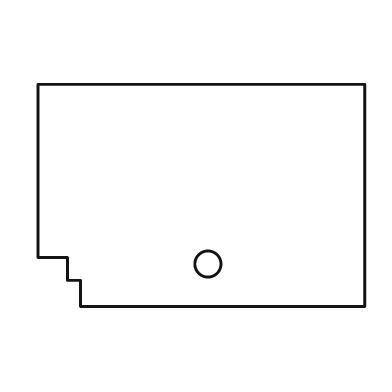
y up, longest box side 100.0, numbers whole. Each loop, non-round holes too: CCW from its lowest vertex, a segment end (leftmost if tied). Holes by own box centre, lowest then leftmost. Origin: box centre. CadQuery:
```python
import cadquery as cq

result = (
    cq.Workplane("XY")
    .moveTo(-37.0, -34.0)
    .lineTo(50.0, -34.0)
    .lineTo(50.0, 34.0)
    .lineTo(-50.0, 34.0)
    .lineTo(-50.0, -19.0)
    .lineTo(-41.0, -19.0)
    .lineTo(-41.0, -26.0)
    .lineTo(-37.0, -26.0)
    .close()
    .moveTo(2.0, -21.0)
    .circle(4.0)
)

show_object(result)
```